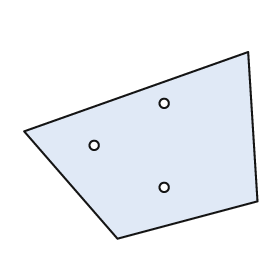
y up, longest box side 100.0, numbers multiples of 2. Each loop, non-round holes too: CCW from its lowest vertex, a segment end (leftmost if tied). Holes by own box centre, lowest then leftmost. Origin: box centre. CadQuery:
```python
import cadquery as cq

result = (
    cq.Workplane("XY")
    .moveTo(-10.0, -40.0)
    .lineTo(50.0, -24.0)
    .lineTo(46.0, 40.0)
    .lineTo(-50.0, 6.0)
    .close()
    .moveTo(10.0, -18.0)
    .circle(2.0)
    .moveTo(-20.0, 0.0)
    .circle(2.0)
    .moveTo(10.0, 18.0)
    .circle(2.0)
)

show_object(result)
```